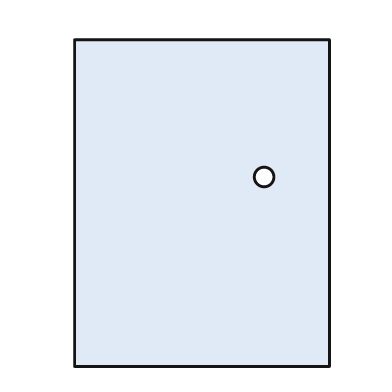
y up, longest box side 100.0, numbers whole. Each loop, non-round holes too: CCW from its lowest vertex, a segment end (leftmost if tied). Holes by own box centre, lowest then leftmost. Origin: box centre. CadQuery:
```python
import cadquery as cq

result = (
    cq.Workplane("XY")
    .moveTo(-39.0, -50.0)
    .lineTo(39.0, -50.0)
    .lineTo(39.0, 50.0)
    .lineTo(-39.0, 50.0)
    .close()
    .moveTo(19.0, 8.0)
    .circle(3.0)
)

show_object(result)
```